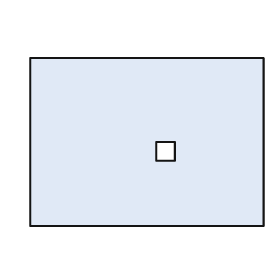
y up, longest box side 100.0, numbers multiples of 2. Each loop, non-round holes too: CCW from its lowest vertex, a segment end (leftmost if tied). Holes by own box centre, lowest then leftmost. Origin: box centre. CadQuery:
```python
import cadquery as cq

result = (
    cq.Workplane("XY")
    .moveTo(-50.0, -36.0)
    .lineTo(50.0, -36.0)
    .lineTo(50.0, 36.0)
    .lineTo(-50.0, 36.0)
    .close()
    .moveTo(4.0, -8.0)
    .lineTo(12.0, -8.0)
    .lineTo(12.0, 0.0)
    .lineTo(4.0, 0.0)
    .close()
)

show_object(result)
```